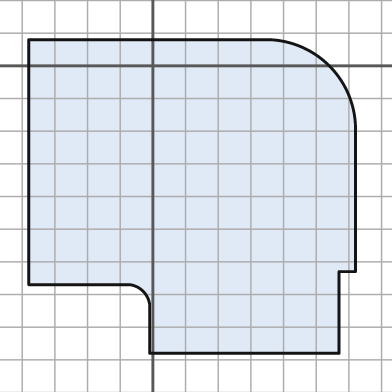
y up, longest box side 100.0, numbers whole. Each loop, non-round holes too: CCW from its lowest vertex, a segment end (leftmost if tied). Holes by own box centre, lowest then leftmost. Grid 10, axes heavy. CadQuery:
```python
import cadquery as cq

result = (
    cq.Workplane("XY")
    .moveTo(-1.0, -88.0)
    .lineTo(57.0, -88.0)
    .lineTo(57.0, -63.0)
    .lineTo(62.0, -63.0)
    .lineTo(62.0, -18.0)
    .threePointArc((54.0, 0.0), (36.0, 8.0))
    .lineTo(-38.0, 8.0)
    .lineTo(-38.0, -67.0)
    .lineTo(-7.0, -67.0)
    .threePointArc((-3.0, -69.0), (-1.0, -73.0))
    .close()
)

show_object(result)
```